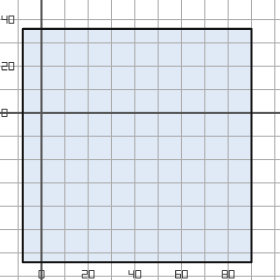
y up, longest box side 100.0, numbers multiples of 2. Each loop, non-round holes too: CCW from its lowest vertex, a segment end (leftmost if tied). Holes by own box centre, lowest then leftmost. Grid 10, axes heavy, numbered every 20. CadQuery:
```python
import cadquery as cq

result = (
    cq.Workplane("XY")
    .moveTo(-8.0, -64.0)
    .lineTo(90.0, -64.0)
    .lineTo(90.0, 36.0)
    .lineTo(-8.0, 36.0)
    .close()
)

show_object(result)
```